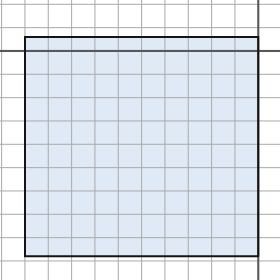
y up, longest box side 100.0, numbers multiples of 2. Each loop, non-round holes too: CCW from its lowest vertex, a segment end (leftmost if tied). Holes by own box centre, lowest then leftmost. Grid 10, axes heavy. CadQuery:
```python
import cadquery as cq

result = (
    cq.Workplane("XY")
    .moveTo(-100.0, -88.0)
    .lineTo(0.0, -88.0)
    .lineTo(0.0, 6.0)
    .lineTo(-100.0, 6.0)
    .close()
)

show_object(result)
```